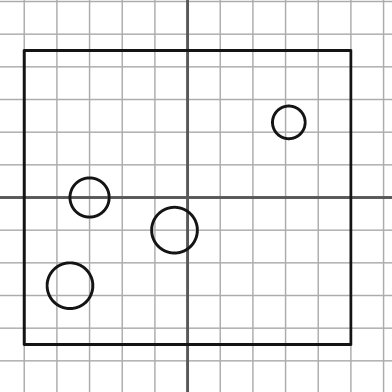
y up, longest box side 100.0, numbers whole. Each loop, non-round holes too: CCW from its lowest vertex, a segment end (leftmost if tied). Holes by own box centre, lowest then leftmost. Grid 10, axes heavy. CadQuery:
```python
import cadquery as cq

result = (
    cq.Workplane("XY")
    .moveTo(-50.0, -45.0)
    .lineTo(50.0, -45.0)
    .lineTo(50.0, 45.0)
    .lineTo(-50.0, 45.0)
    .close()
    .moveTo(-36.0, -27.0)
    .circle(7.0)
    .moveTo(-4.0, -10.0)
    .circle(7.0)
    .moveTo(-30.0, 0.0)
    .circle(6.0)
    .moveTo(31.0, 23.0)
    .circle(5.0)
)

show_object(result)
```